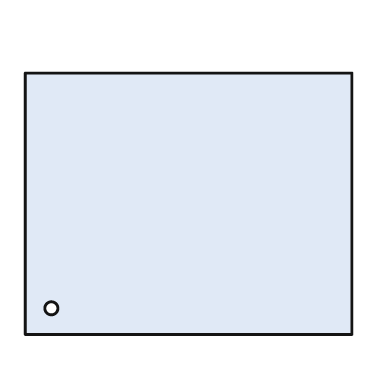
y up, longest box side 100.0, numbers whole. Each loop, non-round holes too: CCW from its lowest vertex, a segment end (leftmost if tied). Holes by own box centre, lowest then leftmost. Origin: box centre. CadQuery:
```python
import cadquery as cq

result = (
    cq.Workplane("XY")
    .moveTo(-50.0, -40.0)
    .lineTo(50.0, -40.0)
    .lineTo(50.0, 40.0)
    .lineTo(-50.0, 40.0)
    .close()
    .moveTo(-42.0, -32.0)
    .circle(2.0)
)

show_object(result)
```